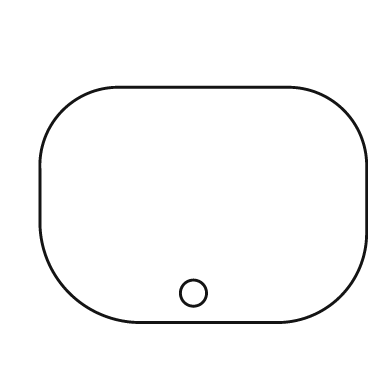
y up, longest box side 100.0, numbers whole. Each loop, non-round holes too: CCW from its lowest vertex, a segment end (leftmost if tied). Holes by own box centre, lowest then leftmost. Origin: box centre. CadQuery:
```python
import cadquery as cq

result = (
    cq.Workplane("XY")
    .moveTo(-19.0, -36.0)
    .lineTo(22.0, -36.0)
    .threePointArc((42.0, -28.0), (50.0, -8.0))
    .lineTo(50.0, 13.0)
    .threePointArc((43.0, 29.0), (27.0, 36.0))
    .lineTo(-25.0, 36.0)
    .threePointArc((-43.0, 29.0), (-50.0, 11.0))
    .lineTo(-50.0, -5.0)
    .threePointArc((-41.0, -27.0), (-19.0, -36.0))
    .close()
    .moveTo(-3.0, -27.0)
    .circle(4.0)
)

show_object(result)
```